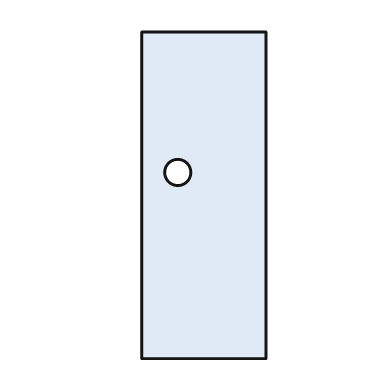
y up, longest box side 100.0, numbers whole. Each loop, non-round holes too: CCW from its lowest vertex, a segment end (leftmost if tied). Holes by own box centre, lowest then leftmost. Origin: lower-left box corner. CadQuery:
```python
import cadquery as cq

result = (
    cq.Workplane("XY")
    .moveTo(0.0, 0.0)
    .lineTo(38.0, 0.0)
    .lineTo(38.0, 100.0)
    .lineTo(0.0, 100.0)
    .close()
    .moveTo(11.0, 57.0)
    .circle(4.0)
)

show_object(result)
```